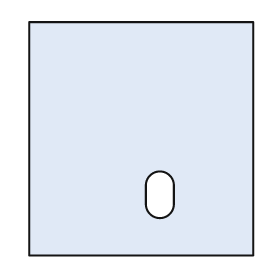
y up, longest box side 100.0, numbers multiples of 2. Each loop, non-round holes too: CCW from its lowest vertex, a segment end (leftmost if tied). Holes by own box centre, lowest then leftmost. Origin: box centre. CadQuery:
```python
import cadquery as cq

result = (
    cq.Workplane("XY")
    .moveTo(-48.0, -50.0)
    .lineTo(48.0, -50.0)
    .lineTo(48.0, 50.0)
    .lineTo(-48.0, 50.0)
    .close()
    .moveTo(2.0, -28.0)
    .threePointArc((8.0, -34.0), (14.0, -28.0))
    .lineTo(14.0, -20.0)
    .threePointArc((8.0, -14.0), (2.0, -20.0))
    .close()
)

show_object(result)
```